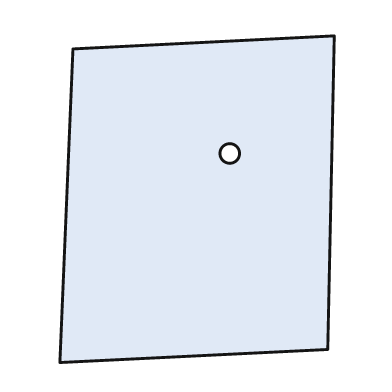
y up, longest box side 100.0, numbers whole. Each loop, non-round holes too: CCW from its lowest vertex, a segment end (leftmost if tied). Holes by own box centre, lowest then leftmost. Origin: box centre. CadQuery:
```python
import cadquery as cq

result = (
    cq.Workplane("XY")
    .moveTo(-42.0, -50.0)
    .lineTo(40.0, -46.0)
    .lineTo(42.0, 50.0)
    .lineTo(-38.0, 46.0)
    .close()
    .moveTo(10.0, 14.0)
    .circle(3.0)
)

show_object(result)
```